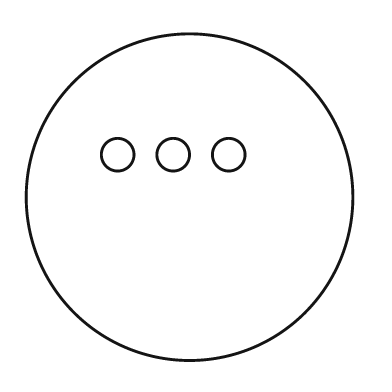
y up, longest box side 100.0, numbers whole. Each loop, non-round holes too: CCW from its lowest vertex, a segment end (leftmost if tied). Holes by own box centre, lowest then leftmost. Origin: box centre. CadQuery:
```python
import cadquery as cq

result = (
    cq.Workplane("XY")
    .moveTo(0.0, 0.0)
    .circle(50.0)
    .moveTo(-22.0, 13.0)
    .circle(5.0)
    .moveTo(-5.0, 13.0)
    .circle(5.0)
    .moveTo(12.0, 13.0)
    .circle(5.0)
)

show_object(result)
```